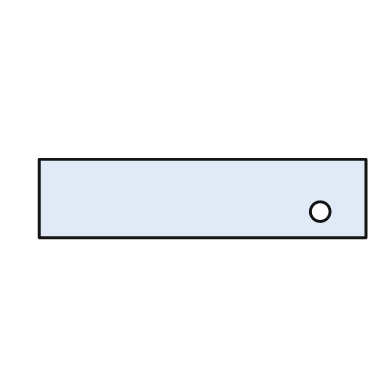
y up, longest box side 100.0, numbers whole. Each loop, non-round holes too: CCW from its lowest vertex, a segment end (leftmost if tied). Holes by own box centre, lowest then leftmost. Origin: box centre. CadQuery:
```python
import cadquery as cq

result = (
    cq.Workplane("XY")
    .moveTo(-50.0, -12.0)
    .lineTo(50.0, -12.0)
    .lineTo(50.0, 12.0)
    .lineTo(-50.0, 12.0)
    .close()
    .moveTo(36.0, -4.0)
    .circle(3.0)
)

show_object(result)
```